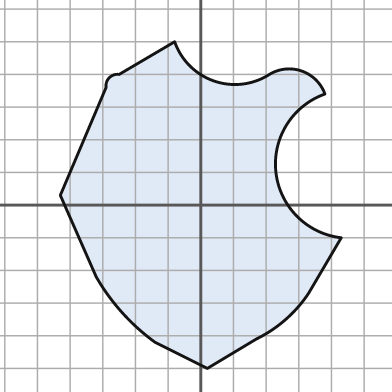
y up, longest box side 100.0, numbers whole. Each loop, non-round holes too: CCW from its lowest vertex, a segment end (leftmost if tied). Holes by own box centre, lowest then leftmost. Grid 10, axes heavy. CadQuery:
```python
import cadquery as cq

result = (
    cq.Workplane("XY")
    .moveTo(2.0, -50.0)
    .lineTo(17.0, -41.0)
    .threePointArc((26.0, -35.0), (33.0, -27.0))
    .lineTo(43.0, -10.0)
    .threePointArc((23.0, 10.0), (38.0, 34.0))
    .threePointArc((31.0, 41.0), (21.0, 40.0))
    .threePointArc((4.0, 38.0), (-8.0, 50.0))
    .lineTo(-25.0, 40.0)
    .threePointArc((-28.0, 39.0), (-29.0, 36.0))
    .lineTo(-43.0, 3.0)
    .lineTo(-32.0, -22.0)
    .threePointArc((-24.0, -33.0), (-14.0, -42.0))
    .close()
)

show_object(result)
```